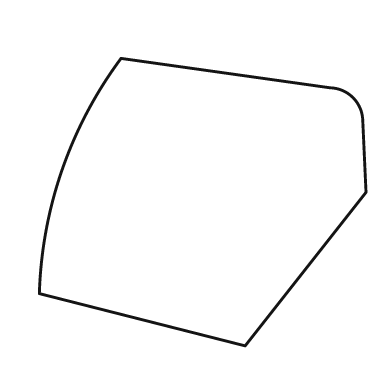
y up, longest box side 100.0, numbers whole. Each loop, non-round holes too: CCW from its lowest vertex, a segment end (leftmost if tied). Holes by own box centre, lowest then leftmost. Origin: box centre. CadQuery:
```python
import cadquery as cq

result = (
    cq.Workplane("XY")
    .moveTo(13.0, -44.0)
    .lineTo(50.0, 3.0)
    .lineTo(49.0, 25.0)
    .threePointArc((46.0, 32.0), (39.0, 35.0))
    .lineTo(-25.0, 44.0)
    .threePointArc((-43.0, 10.0), (-50.0, -28.0))
    .close()
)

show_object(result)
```